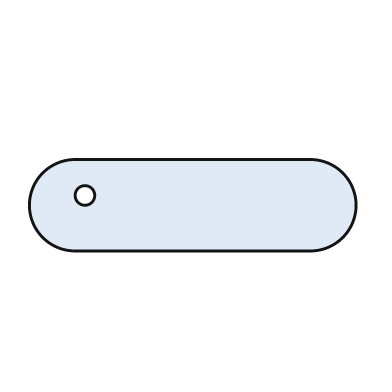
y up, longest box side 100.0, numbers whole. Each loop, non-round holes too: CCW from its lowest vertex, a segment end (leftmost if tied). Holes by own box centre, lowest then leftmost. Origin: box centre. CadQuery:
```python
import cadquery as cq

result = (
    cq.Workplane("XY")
    .moveTo(-36.0, -14.0)
    .lineTo(36.0, -14.0)
    .threePointArc((50.0, 0.0), (36.0, 14.0))
    .lineTo(-36.0, 14.0)
    .threePointArc((-50.0, 0.0), (-36.0, -14.0))
    .close()
    .moveTo(-33.0, 3.0)
    .circle(3.0)
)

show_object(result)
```